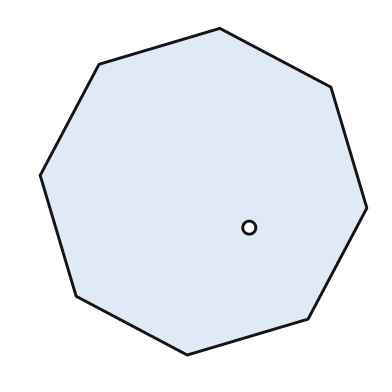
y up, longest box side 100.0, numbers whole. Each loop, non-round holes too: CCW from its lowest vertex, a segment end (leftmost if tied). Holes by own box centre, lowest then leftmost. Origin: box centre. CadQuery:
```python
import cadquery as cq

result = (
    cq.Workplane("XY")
    .moveTo(-5.0, -50.0)
    .lineTo(32.0, -39.0)
    .lineTo(50.0, -5.0)
    .lineTo(39.0, 32.0)
    .lineTo(5.0, 50.0)
    .lineTo(-32.0, 39.0)
    .lineTo(-50.0, 5.0)
    .lineTo(-39.0, -32.0)
    .close()
    .moveTo(14.0, -11.0)
    .circle(2.0)
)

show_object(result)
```